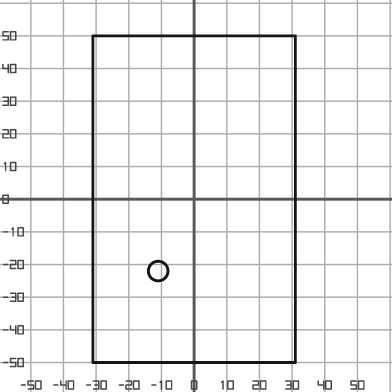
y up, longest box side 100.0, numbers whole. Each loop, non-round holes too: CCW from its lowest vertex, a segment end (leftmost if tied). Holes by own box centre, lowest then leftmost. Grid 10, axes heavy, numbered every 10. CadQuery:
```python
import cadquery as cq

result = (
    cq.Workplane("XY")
    .moveTo(-31.0, -50.0)
    .lineTo(31.0, -50.0)
    .lineTo(31.0, 50.0)
    .lineTo(-31.0, 50.0)
    .close()
    .moveTo(-11.0, -22.0)
    .circle(3.0)
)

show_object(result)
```